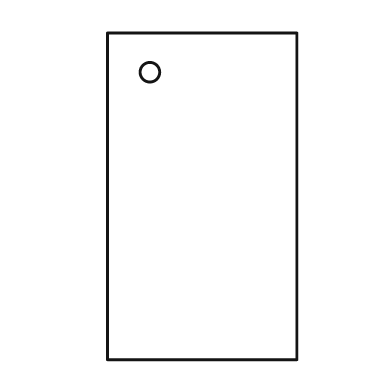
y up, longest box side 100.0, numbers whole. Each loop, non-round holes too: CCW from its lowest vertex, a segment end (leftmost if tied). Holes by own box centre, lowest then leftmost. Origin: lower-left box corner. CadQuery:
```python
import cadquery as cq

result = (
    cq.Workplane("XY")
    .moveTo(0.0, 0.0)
    .lineTo(58.0, 0.0)
    .lineTo(58.0, 100.0)
    .lineTo(0.0, 100.0)
    .close()
    .moveTo(13.0, 88.0)
    .circle(3.0)
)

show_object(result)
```